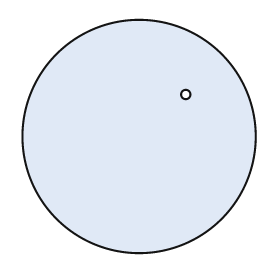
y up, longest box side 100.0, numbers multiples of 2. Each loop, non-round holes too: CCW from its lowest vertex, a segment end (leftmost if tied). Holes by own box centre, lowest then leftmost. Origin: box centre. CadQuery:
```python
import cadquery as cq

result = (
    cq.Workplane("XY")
    .moveTo(0.0, 0.0)
    .circle(50.0)
    .moveTo(20.0, 18.0)
    .circle(2.0)
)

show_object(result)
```